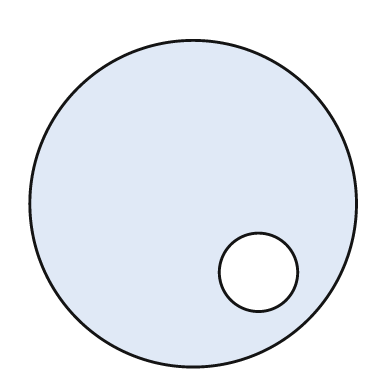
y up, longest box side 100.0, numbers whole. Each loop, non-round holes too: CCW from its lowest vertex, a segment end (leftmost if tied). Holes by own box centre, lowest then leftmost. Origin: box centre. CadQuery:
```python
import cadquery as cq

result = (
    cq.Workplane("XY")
    .moveTo(0.0, 0.0)
    .circle(50.0)
    .moveTo(20.0, -21.0)
    .circle(12.0)
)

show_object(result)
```